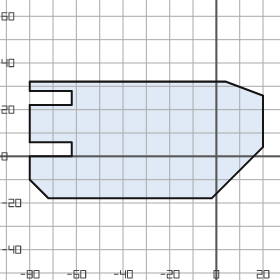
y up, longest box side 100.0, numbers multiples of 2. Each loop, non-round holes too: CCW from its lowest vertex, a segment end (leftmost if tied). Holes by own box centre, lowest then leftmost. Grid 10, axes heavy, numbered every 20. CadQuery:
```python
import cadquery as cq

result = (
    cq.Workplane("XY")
    .moveTo(-72.0, -18.0)
    .lineTo(-2.0, -18.0)
    .lineTo(20.0, 4.0)
    .lineTo(20.0, 26.0)
    .lineTo(4.0, 32.0)
    .lineTo(-80.0, 32.0)
    .lineTo(-80.0, 28.0)
    .lineTo(-62.0, 28.0)
    .lineTo(-62.0, 22.0)
    .lineTo(-80.0, 22.0)
    .lineTo(-80.0, 6.0)
    .lineTo(-62.0, 6.0)
    .lineTo(-62.0, 0.0)
    .lineTo(-80.0, 0.0)
    .lineTo(-80.0, -10.0)
    .close()
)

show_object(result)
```